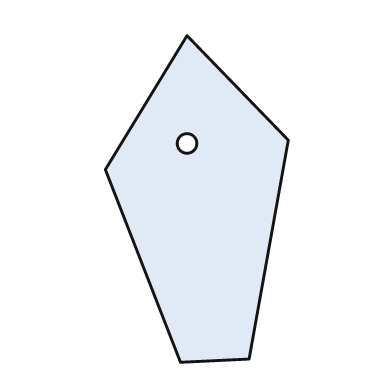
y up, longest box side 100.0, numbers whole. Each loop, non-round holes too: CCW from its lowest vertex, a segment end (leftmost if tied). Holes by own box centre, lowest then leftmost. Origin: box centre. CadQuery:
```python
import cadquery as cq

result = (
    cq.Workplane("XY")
    .moveTo(-5.0, -50.0)
    .lineTo(16.0, -49.0)
    .lineTo(28.0, 18.0)
    .lineTo(-3.0, 50.0)
    .lineTo(-28.0, 9.0)
    .close()
    .moveTo(-3.0, 17.0)
    .circle(3.0)
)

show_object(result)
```